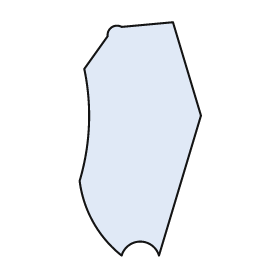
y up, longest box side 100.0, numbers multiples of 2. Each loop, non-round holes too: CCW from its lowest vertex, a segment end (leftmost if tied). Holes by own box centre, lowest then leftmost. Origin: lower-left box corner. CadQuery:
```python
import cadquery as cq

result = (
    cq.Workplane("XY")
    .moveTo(18.0, 0.0)
    .threePointArc((26.0, 6.0), (34.0, 0.0))
    .lineTo(52.0, 60.0)
    .lineTo(40.0, 100.0)
    .lineTo(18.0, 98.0)
    .threePointArc((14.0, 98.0), (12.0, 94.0))
    .lineTo(2.0, 80.0)
    .threePointArc((4.0, 56.0), (0.0, 32.0))
    .threePointArc((6.0, 14.0), (18.0, 0.0))
    .close()
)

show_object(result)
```